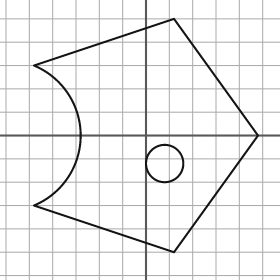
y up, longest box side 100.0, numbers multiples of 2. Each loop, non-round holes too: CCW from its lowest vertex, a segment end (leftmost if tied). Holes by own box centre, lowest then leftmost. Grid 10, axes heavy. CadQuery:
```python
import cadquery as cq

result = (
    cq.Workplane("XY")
    .moveTo(12.0, -50.0)
    .lineTo(48.0, 0.0)
    .lineTo(12.0, 50.0)
    .lineTo(-48.0, 30.0)
    .threePointArc((-28.0, 0.0), (-48.0, -30.0))
    .close()
    .moveTo(8.0, -12.0)
    .circle(8.0)
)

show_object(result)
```